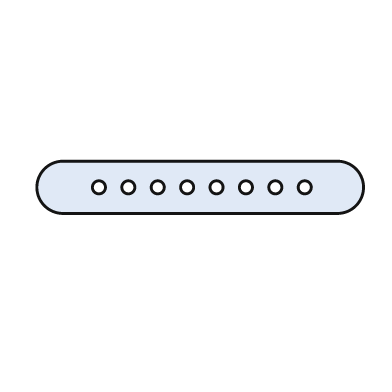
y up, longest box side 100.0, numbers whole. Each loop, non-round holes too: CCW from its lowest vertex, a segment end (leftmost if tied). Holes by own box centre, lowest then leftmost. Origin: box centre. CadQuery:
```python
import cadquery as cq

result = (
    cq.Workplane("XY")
    .moveTo(-42.0, -8.0)
    .lineTo(42.0, -8.0)
    .threePointArc((50.0, 0.0), (42.0, 8.0))
    .lineTo(-42.0, 8.0)
    .threePointArc((-50.0, 0.0), (-42.0, -8.0))
    .close()
    .moveTo(-31.0, 0.0)
    .circle(2.0)
    .moveTo(-22.0, 0.0)
    .circle(2.0)
    .moveTo(-13.0, 0.0)
    .circle(2.0)
    .moveTo(-4.0, 0.0)
    .circle(2.0)
    .moveTo(5.0, 0.0)
    .circle(2.0)
    .moveTo(14.0, 0.0)
    .circle(2.0)
    .moveTo(23.0, 0.0)
    .circle(2.0)
    .moveTo(32.0, 0.0)
    .circle(2.0)
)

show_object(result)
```